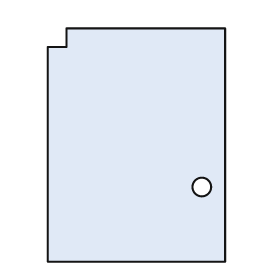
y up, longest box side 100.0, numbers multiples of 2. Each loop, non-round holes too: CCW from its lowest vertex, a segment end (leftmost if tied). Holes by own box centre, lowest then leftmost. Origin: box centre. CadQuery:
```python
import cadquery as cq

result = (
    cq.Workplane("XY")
    .moveTo(-38.0, -50.0)
    .lineTo(38.0, -50.0)
    .lineTo(38.0, 50.0)
    .lineTo(-30.0, 50.0)
    .lineTo(-30.0, 42.0)
    .lineTo(-38.0, 42.0)
    .close()
    .moveTo(28.0, -18.0)
    .circle(4.0)
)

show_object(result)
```